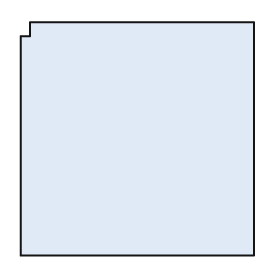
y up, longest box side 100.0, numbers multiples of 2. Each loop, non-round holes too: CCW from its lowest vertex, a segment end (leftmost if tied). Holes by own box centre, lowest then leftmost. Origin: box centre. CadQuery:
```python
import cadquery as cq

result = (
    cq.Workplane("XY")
    .moveTo(-50.0, -50.0)
    .lineTo(50.0, -50.0)
    .lineTo(50.0, 50.0)
    .lineTo(-46.0, 50.0)
    .lineTo(-46.0, 44.0)
    .lineTo(-50.0, 44.0)
    .close()
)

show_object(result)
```